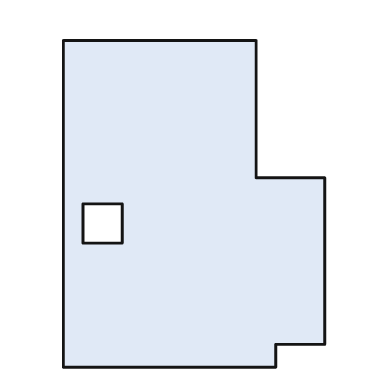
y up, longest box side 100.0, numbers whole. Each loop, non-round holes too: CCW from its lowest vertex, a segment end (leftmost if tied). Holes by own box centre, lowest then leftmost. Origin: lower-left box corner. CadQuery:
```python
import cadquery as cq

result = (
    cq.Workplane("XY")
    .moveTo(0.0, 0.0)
    .lineTo(65.0, 0.0)
    .lineTo(65.0, 7.0)
    .lineTo(80.0, 7.0)
    .lineTo(80.0, 58.0)
    .lineTo(59.0, 58.0)
    .lineTo(59.0, 100.0)
    .lineTo(0.0, 100.0)
    .close()
    .moveTo(6.0, 38.0)
    .lineTo(18.0, 38.0)
    .lineTo(18.0, 50.0)
    .lineTo(6.0, 50.0)
    .close()
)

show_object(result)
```